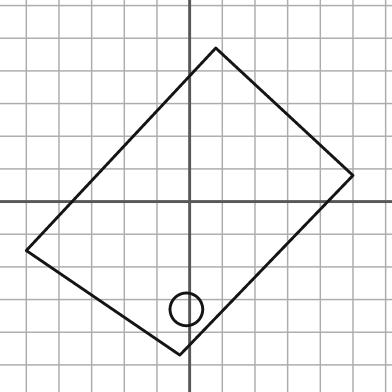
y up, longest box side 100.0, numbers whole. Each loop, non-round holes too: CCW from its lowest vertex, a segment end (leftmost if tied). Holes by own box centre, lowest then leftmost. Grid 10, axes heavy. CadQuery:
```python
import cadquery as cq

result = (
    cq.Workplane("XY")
    .moveTo(-3.0, -47.0)
    .lineTo(50.0, 8.0)
    .lineTo(8.0, 47.0)
    .lineTo(-50.0, -15.0)
    .close()
    .moveTo(-1.0, -33.0)
    .circle(5.0)
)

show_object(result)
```